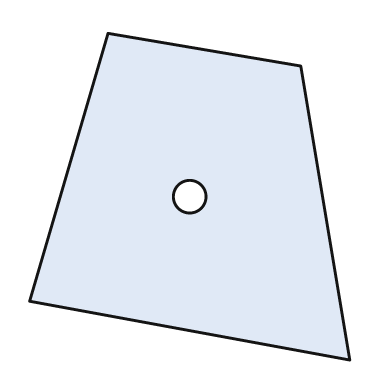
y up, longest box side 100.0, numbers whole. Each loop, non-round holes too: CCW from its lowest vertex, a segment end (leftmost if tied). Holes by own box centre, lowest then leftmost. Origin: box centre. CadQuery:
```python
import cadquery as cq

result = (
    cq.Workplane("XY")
    .moveTo(49.0, -50.0)
    .lineTo(34.0, 40.0)
    .lineTo(-25.0, 50.0)
    .lineTo(-49.0, -32.0)
    .close()
    .moveTo(0.0, 0.0)
    .circle(5.0)
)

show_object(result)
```